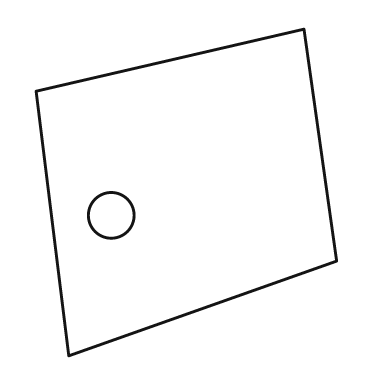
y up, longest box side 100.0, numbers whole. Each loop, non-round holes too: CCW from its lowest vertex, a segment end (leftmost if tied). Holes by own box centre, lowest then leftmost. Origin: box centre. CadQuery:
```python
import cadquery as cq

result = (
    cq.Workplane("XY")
    .moveTo(-36.0, -50.0)
    .lineTo(46.0, -21.0)
    .lineTo(36.0, 50.0)
    .lineTo(-46.0, 31.0)
    .close()
    .moveTo(-23.0, -7.0)
    .circle(7.0)
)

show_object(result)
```